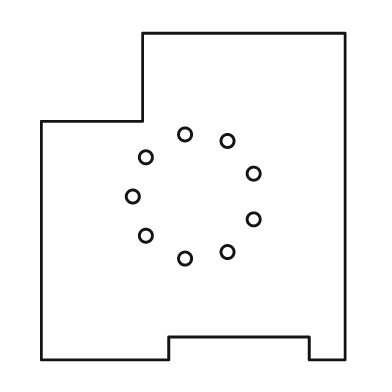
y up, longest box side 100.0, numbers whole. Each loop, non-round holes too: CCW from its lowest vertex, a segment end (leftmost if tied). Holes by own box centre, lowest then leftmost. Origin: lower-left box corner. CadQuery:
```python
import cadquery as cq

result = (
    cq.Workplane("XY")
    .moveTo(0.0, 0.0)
    .lineTo(39.0, 0.0)
    .lineTo(39.0, 7.0)
    .lineTo(82.0, 7.0)
    .lineTo(82.0, 0.0)
    .lineTo(93.0, 0.0)
    .lineTo(93.0, 100.0)
    .lineTo(31.0, 100.0)
    .lineTo(31.0, 73.0)
    .lineTo(0.0, 73.0)
    .close()
    .moveTo(44.0, 31.0)
    .circle(2.0)
    .moveTo(57.0, 33.0)
    .circle(2.0)
    .moveTo(32.0, 38.0)
    .circle(2.0)
    .moveTo(65.0, 43.0)
    .circle(2.0)
    .moveTo(28.0, 50.0)
    .circle(2.0)
    .moveTo(65.0, 57.0)
    .circle(2.0)
    .moveTo(32.0, 62.0)
    .circle(2.0)
    .moveTo(57.0, 67.0)
    .circle(2.0)
    .moveTo(44.0, 69.0)
    .circle(2.0)
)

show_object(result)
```